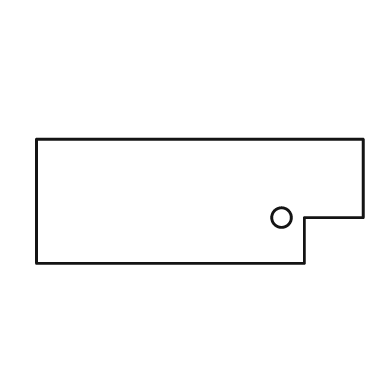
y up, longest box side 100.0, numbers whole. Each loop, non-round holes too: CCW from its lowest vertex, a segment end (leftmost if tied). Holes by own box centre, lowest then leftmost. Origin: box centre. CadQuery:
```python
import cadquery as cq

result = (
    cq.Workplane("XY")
    .moveTo(-50.0, -19.0)
    .lineTo(32.0, -19.0)
    .lineTo(32.0, -5.0)
    .lineTo(50.0, -5.0)
    .lineTo(50.0, 19.0)
    .lineTo(-50.0, 19.0)
    .close()
    .moveTo(25.0, -5.0)
    .circle(3.0)
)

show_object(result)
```